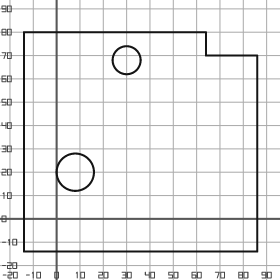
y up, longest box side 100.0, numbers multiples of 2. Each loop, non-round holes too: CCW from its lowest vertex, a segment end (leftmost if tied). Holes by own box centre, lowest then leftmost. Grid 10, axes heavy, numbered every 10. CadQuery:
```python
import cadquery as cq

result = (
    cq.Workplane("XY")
    .moveTo(-14.0, -14.0)
    .lineTo(86.0, -14.0)
    .lineTo(86.0, 70.0)
    .lineTo(64.0, 70.0)
    .lineTo(64.0, 80.0)
    .lineTo(-14.0, 80.0)
    .close()
    .moveTo(8.0, 20.0)
    .circle(8.0)
    .moveTo(30.0, 68.0)
    .circle(6.0)
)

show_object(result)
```